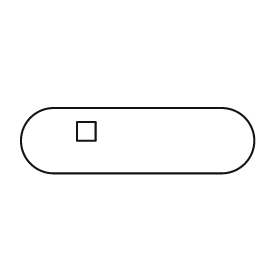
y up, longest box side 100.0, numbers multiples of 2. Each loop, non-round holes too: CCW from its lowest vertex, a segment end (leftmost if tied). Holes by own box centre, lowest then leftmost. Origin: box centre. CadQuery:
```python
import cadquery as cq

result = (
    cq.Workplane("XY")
    .moveTo(-36.0, -14.0)
    .lineTo(36.0, -14.0)
    .threePointArc((50.0, 0.0), (36.0, 14.0))
    .lineTo(-36.0, 14.0)
    .threePointArc((-50.0, 0.0), (-36.0, -14.0))
    .close()
    .moveTo(-26.0, 0.0)
    .lineTo(-18.0, 0.0)
    .lineTo(-18.0, 8.0)
    .lineTo(-26.0, 8.0)
    .close()
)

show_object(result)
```